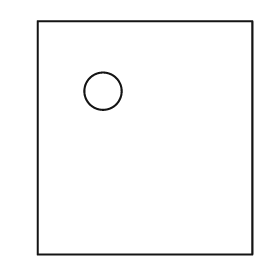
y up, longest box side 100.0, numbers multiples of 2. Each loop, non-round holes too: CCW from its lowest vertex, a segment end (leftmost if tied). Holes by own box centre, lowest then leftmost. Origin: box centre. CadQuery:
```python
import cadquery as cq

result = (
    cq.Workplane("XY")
    .moveTo(-46.0, -50.0)
    .lineTo(46.0, -50.0)
    .lineTo(46.0, 50.0)
    .lineTo(-46.0, 50.0)
    .close()
    .moveTo(-18.0, 20.0)
    .circle(8.0)
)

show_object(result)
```